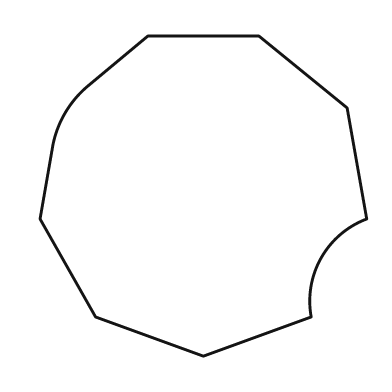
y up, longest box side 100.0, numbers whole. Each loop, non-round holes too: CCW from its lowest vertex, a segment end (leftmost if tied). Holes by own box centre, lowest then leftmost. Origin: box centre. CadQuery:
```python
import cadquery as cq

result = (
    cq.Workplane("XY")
    .moveTo(0.0, -49.0)
    .lineTo(33.0, -37.0)
    .threePointArc((36.0, -19.0), (50.0, -7.0))
    .lineTo(44.0, 27.0)
    .lineTo(17.0, 49.0)
    .lineTo(-17.0, 49.0)
    .lineTo(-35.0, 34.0)
    .threePointArc((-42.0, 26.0), (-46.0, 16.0))
    .lineTo(-50.0, -7.0)
    .lineTo(-33.0, -37.0)
    .close()
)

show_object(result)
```